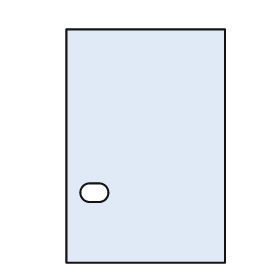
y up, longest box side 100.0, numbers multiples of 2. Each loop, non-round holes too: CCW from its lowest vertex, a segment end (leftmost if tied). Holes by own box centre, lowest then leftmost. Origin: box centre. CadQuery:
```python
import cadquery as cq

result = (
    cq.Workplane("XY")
    .moveTo(-34.0, -50.0)
    .lineTo(34.0, -50.0)
    .lineTo(34.0, 50.0)
    .lineTo(-34.0, 50.0)
    .close()
    .moveTo(-24.0, -24.0)
    .lineTo(-20.0, -24.0)
    .threePointArc((-16.0, -20.0), (-20.0, -16.0))
    .lineTo(-24.0, -16.0)
    .threePointArc((-28.0, -20.0), (-24.0, -24.0))
    .close()
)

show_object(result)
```